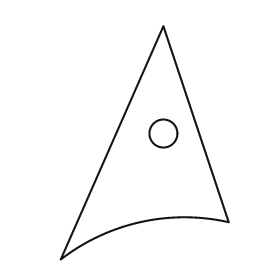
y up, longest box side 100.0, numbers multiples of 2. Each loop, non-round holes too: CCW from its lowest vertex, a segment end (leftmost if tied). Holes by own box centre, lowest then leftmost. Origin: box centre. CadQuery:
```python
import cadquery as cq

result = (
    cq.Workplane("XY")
    .moveTo(-36.0, -50.0)
    .threePointArc((-2.0, -34.0), (36.0, -34.0))
    .lineTo(8.0, 50.0)
    .close()
    .moveTo(8.0, 4.0)
    .circle(6.0)
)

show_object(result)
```